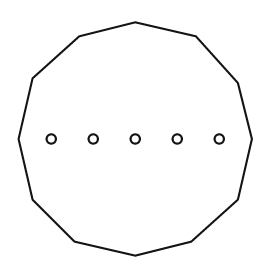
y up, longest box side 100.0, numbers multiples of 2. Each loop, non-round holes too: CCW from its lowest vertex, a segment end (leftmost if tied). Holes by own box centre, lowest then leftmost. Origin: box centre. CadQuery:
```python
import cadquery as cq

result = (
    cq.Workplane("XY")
    .moveTo(0.0, -50.0)
    .lineTo(24.0, -44.0)
    .lineTo(44.0, -26.0)
    .lineTo(50.0, 0.0)
    .lineTo(44.0, 24.0)
    .lineTo(26.0, 44.0)
    .lineTo(0.0, 50.0)
    .lineTo(-24.0, 44.0)
    .lineTo(-44.0, 26.0)
    .lineTo(-50.0, 0.0)
    .lineTo(-44.0, -26.0)
    .lineTo(-26.0, -44.0)
    .close()
    .moveTo(-36.0, 0.0)
    .circle(2.0)
    .moveTo(-18.0, 0.0)
    .circle(2.0)
    .moveTo(0.0, 0.0)
    .circle(2.0)
    .moveTo(18.0, 0.0)
    .circle(2.0)
    .moveTo(36.0, 0.0)
    .circle(2.0)
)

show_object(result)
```